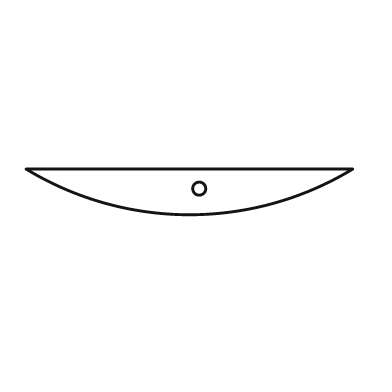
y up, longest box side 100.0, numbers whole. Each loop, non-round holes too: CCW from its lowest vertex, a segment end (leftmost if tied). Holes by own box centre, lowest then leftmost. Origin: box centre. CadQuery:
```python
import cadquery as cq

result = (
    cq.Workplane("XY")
    .moveTo(-50.0, 7.0)
    .threePointArc((0.0, -7.0), (50.0, 7.0))
    .close()
    .moveTo(3.0, 1.0)
    .circle(2.0)
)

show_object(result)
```